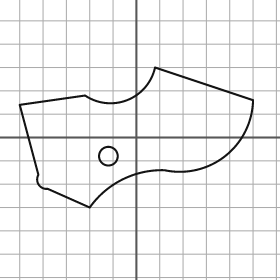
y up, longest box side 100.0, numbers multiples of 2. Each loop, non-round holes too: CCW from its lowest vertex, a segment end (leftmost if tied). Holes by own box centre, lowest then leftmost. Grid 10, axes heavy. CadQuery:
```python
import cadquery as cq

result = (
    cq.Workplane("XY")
    .moveTo(-20.0, -30.0)
    .threePointArc((-6.0, -18.0), (12.0, -14.0))
    .threePointArc((38.0, -8.0), (50.0, 16.0))
    .lineTo(8.0, 30.0)
    .threePointArc((-4.0, 16.0), (-22.0, 18.0))
    .lineTo(-50.0, 14.0)
    .lineTo(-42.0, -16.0)
    .threePointArc((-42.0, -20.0), (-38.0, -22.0))
    .close()
    .moveTo(-12.0, -8.0)
    .circle(4.0)
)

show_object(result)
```